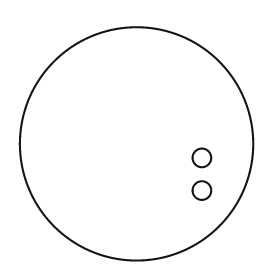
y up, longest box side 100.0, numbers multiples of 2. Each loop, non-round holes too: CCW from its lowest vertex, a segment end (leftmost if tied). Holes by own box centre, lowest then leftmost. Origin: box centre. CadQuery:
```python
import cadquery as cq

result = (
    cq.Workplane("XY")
    .moveTo(0.0, 0.0)
    .circle(50.0)
    .moveTo(28.0, -20.0)
    .circle(4.0)
    .moveTo(28.0, -6.0)
    .circle(4.0)
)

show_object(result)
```